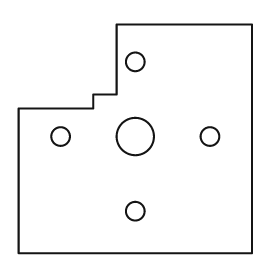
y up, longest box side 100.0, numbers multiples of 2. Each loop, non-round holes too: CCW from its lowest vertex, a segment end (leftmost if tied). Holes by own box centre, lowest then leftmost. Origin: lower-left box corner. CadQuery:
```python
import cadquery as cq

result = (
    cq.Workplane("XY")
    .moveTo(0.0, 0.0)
    .lineTo(100.0, 0.0)
    .lineTo(100.0, 98.0)
    .lineTo(42.0, 98.0)
    .lineTo(42.0, 68.0)
    .lineTo(32.0, 68.0)
    .lineTo(32.0, 62.0)
    .lineTo(0.0, 62.0)
    .close()
    .moveTo(50.0, 18.0)
    .circle(4.0)
    .moveTo(18.0, 50.0)
    .circle(4.0)
    .moveTo(50.0, 50.0)
    .circle(8.0)
    .moveTo(82.0, 50.0)
    .circle(4.0)
    .moveTo(50.0, 82.0)
    .circle(4.0)
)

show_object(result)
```